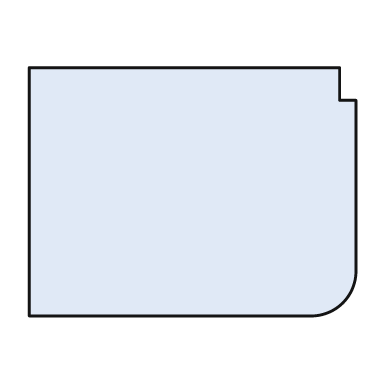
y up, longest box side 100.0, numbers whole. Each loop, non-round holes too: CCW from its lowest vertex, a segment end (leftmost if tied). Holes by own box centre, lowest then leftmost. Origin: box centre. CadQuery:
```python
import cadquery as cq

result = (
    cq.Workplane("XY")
    .moveTo(-50.0, -38.0)
    .lineTo(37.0, -38.0)
    .threePointArc((46.0, -34.0), (50.0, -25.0))
    .lineTo(50.0, 28.0)
    .lineTo(45.0, 28.0)
    .lineTo(45.0, 38.0)
    .lineTo(-50.0, 38.0)
    .close()
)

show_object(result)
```